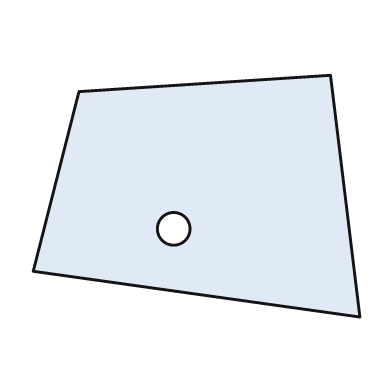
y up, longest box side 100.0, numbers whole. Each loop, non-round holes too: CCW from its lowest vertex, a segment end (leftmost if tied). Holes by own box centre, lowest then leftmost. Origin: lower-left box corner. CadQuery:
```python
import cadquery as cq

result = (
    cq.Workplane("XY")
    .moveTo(100.0, 0.0)
    .lineTo(91.0, 74.0)
    .lineTo(14.0, 69.0)
    .lineTo(0.0, 14.0)
    .close()
    .moveTo(43.0, 27.0)
    .circle(5.0)
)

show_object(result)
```